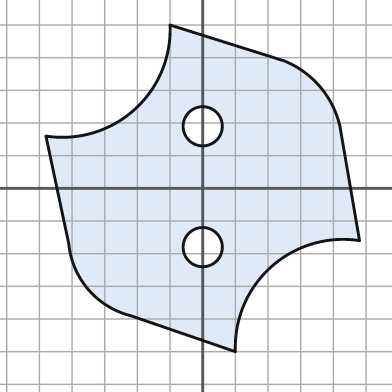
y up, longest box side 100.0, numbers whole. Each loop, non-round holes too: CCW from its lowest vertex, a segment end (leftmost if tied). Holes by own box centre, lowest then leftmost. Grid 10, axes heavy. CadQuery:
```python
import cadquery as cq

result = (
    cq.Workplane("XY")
    .moveTo(10.0, -50.0)
    .threePointArc((21.0, -24.0), (48.0, -16.0))
    .lineTo(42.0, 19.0)
    .threePointArc((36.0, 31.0), (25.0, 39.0))
    .lineTo(-10.0, 50.0)
    .threePointArc((-21.0, 24.0), (-48.0, 16.0))
    .lineTo(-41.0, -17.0)
    .threePointArc((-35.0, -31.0), (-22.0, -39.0))
    .close()
    .moveTo(0.0, -18.0)
    .circle(6.0)
    .moveTo(0.0, 19.0)
    .circle(6.0)
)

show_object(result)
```